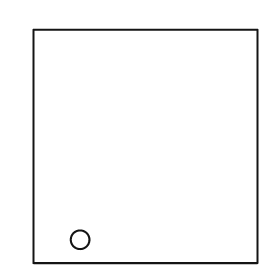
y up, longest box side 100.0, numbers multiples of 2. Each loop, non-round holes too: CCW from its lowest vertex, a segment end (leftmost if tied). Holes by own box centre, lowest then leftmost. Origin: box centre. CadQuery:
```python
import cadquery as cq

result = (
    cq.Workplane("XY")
    .moveTo(-48.0, -50.0)
    .lineTo(48.0, -50.0)
    .lineTo(48.0, 50.0)
    .lineTo(-48.0, 50.0)
    .close()
    .moveTo(-28.0, -40.0)
    .circle(4.0)
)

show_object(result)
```